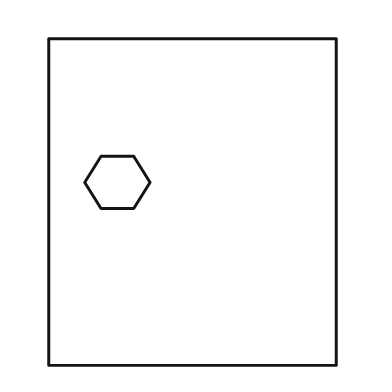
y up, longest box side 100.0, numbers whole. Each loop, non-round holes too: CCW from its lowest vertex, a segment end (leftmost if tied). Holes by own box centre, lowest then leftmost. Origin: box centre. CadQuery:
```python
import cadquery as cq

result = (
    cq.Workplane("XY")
    .moveTo(-44.0, -50.0)
    .lineTo(44.0, -50.0)
    .lineTo(44.0, 50.0)
    .lineTo(-44.0, 50.0)
    .close()
    .moveTo(-28.0, -2.0)
    .lineTo(-18.0, -2.0)
    .lineTo(-13.0, 6.0)
    .lineTo(-18.0, 14.0)
    .lineTo(-28.0, 14.0)
    .lineTo(-33.0, 6.0)
    .close()
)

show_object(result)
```